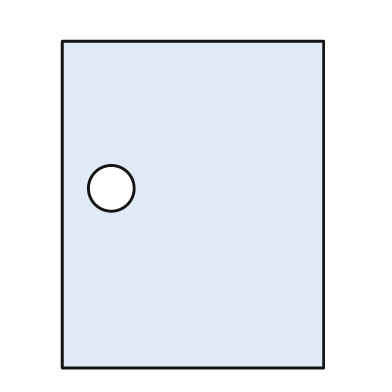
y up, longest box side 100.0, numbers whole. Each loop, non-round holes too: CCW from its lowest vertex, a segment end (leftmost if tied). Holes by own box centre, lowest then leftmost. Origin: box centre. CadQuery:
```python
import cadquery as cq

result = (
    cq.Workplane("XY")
    .moveTo(-40.0, -50.0)
    .lineTo(40.0, -50.0)
    .lineTo(40.0, 50.0)
    .lineTo(-40.0, 50.0)
    .close()
    .moveTo(-25.0, 5.0)
    .circle(7.0)
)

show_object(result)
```